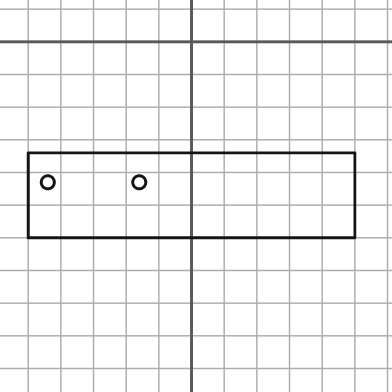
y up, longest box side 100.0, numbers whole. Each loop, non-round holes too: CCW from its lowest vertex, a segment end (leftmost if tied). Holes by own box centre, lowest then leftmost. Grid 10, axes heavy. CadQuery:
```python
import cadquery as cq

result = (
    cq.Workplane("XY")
    .moveTo(-50.0, -60.0)
    .lineTo(50.0, -60.0)
    .lineTo(50.0, -34.0)
    .lineTo(-50.0, -34.0)
    .close()
    .moveTo(-44.0, -43.0)
    .circle(2.0)
    .moveTo(-16.0, -43.0)
    .circle(2.0)
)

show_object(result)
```